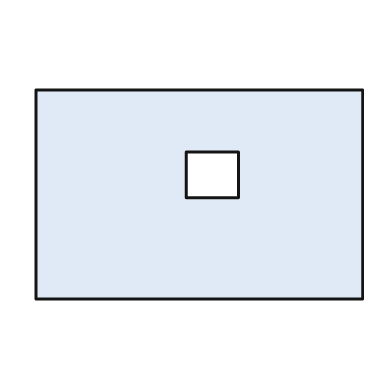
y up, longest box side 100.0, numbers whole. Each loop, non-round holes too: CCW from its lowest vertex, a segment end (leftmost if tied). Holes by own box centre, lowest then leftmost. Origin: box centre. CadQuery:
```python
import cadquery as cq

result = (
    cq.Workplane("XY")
    .moveTo(-50.0, -32.0)
    .lineTo(50.0, -32.0)
    .lineTo(50.0, 32.0)
    .lineTo(-50.0, 32.0)
    .close()
    .moveTo(-4.0, -1.0)
    .lineTo(12.0, -1.0)
    .lineTo(12.0, 13.0)
    .lineTo(-4.0, 13.0)
    .close()
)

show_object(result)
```